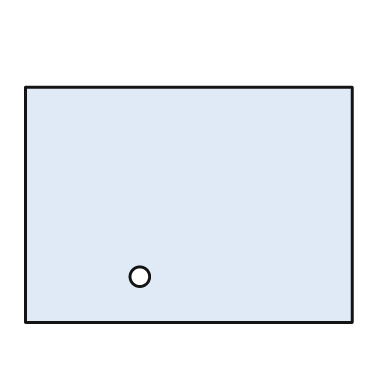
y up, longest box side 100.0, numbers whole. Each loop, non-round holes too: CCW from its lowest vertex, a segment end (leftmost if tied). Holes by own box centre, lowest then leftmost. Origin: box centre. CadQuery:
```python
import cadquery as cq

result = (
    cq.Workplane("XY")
    .moveTo(-50.0, -36.0)
    .lineTo(50.0, -36.0)
    .lineTo(50.0, 36.0)
    .lineTo(-50.0, 36.0)
    .close()
    .moveTo(-15.0, -22.0)
    .circle(3.0)
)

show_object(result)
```